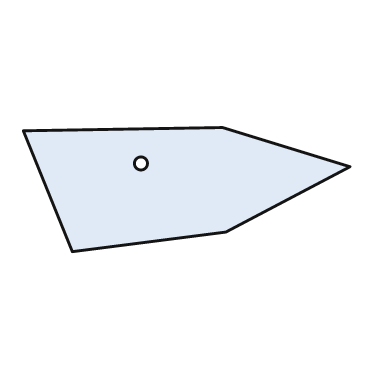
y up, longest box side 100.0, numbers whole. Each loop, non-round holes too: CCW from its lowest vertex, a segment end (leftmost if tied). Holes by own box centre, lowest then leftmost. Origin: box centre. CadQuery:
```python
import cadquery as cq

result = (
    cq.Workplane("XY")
    .moveTo(-35.0, -19.0)
    .lineTo(12.0, -13.0)
    .lineTo(50.0, 7.0)
    .lineTo(11.0, 19.0)
    .lineTo(-50.0, 18.0)
    .close()
    .moveTo(-14.0, 8.0)
    .circle(2.0)
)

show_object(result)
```